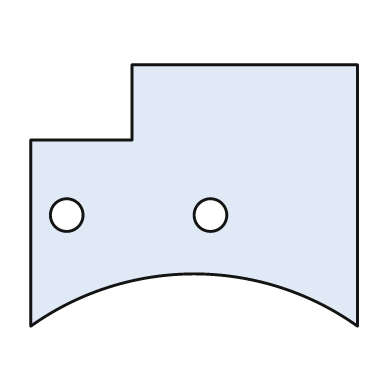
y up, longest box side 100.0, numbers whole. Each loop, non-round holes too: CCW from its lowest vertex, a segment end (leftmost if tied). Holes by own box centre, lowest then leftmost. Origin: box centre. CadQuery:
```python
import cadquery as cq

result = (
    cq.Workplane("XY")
    .moveTo(-50.0, -40.0)
    .threePointArc((0.0, -24.0), (50.0, -40.0))
    .lineTo(50.0, 40.0)
    .lineTo(-19.0, 40.0)
    .lineTo(-19.0, 17.0)
    .lineTo(-50.0, 17.0)
    .close()
    .moveTo(-39.0, -6.0)
    .circle(5.0)
    .moveTo(5.0, -6.0)
    .circle(5.0)
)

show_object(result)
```